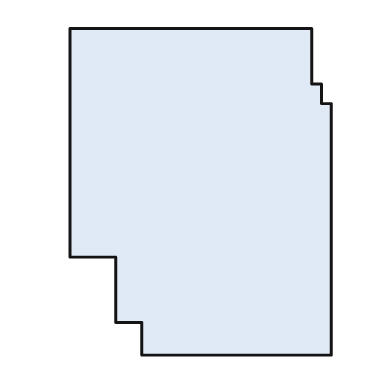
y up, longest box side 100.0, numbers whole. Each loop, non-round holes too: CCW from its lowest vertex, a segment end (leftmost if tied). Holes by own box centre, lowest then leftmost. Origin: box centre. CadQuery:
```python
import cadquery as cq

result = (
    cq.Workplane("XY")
    .moveTo(-18.0, -50.0)
    .lineTo(40.0, -50.0)
    .lineTo(40.0, 27.0)
    .lineTo(37.0, 27.0)
    .lineTo(37.0, 33.0)
    .lineTo(34.0, 33.0)
    .lineTo(34.0, 50.0)
    .lineTo(-40.0, 50.0)
    .lineTo(-40.0, -20.0)
    .lineTo(-26.0, -20.0)
    .lineTo(-26.0, -40.0)
    .lineTo(-18.0, -40.0)
    .close()
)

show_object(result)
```